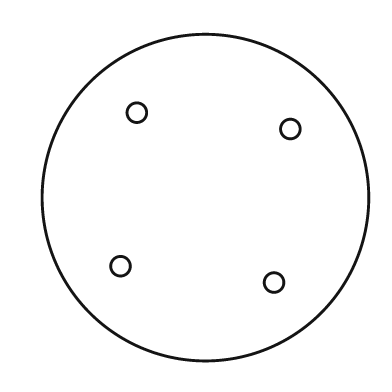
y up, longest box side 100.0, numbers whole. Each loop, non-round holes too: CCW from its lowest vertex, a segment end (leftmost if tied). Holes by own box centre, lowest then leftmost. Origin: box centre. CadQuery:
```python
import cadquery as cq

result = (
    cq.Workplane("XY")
    .moveTo(0.0, 0.0)
    .circle(50.0)
    .moveTo(21.0, -26.0)
    .circle(3.0)
    .moveTo(-26.0, -21.0)
    .circle(3.0)
    .moveTo(26.0, 21.0)
    .circle(3.0)
    .moveTo(-21.0, 26.0)
    .circle(3.0)
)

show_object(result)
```